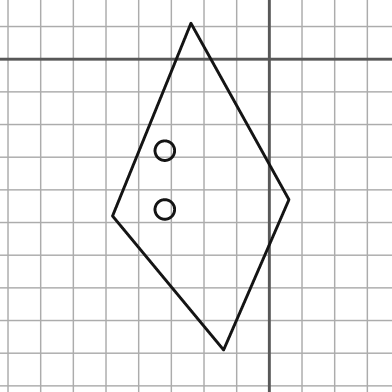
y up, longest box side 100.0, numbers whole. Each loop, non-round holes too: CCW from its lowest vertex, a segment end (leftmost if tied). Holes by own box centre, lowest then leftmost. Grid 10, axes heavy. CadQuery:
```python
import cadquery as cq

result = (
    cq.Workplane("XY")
    .moveTo(-14.0, -89.0)
    .lineTo(6.0, -43.0)
    .lineTo(-24.0, 11.0)
    .lineTo(-48.0, -48.0)
    .close()
    .moveTo(-32.0, -46.0)
    .circle(3.0)
    .moveTo(-32.0, -28.0)
    .circle(3.0)
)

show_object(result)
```